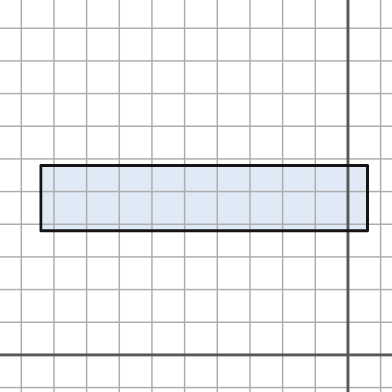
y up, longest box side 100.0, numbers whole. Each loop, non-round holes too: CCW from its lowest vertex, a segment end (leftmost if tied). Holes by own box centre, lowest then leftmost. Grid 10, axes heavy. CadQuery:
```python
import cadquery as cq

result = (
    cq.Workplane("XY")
    .moveTo(-94.0, 38.0)
    .lineTo(6.0, 38.0)
    .lineTo(6.0, 58.0)
    .lineTo(-94.0, 58.0)
    .close()
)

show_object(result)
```